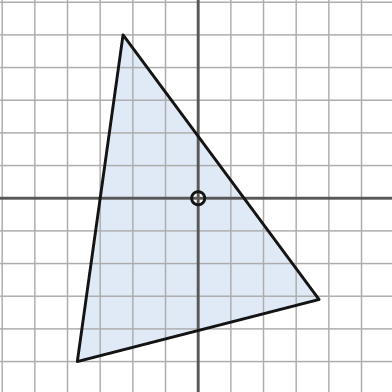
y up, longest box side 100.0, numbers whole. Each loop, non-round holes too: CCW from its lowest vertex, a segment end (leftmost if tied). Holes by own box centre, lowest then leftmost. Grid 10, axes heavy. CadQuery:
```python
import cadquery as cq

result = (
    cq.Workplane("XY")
    .moveTo(-37.0, -50.0)
    .lineTo(37.0, -31.0)
    .lineTo(-23.0, 50.0)
    .close()
    .moveTo(0.0, 0.0)
    .circle(2.0)
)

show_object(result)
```